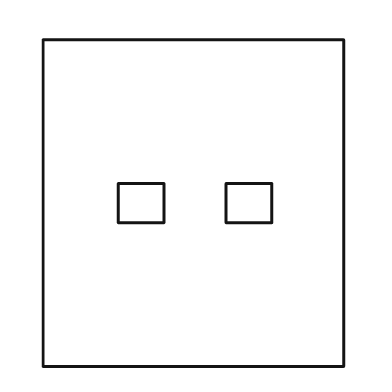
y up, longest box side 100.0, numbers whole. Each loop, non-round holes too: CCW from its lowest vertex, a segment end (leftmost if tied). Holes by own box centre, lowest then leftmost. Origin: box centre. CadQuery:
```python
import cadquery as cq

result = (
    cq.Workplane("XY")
    .moveTo(-46.0, -50.0)
    .lineTo(46.0, -50.0)
    .lineTo(46.0, 50.0)
    .lineTo(-46.0, 50.0)
    .close()
    .moveTo(-23.0, -6.0)
    .lineTo(-9.0, -6.0)
    .lineTo(-9.0, 6.0)
    .lineTo(-23.0, 6.0)
    .close()
    .moveTo(10.0, -6.0)
    .lineTo(24.0, -6.0)
    .lineTo(24.0, 6.0)
    .lineTo(10.0, 6.0)
    .close()
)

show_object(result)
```